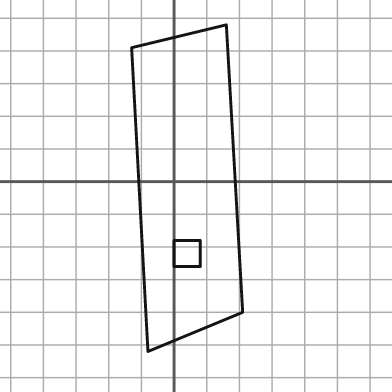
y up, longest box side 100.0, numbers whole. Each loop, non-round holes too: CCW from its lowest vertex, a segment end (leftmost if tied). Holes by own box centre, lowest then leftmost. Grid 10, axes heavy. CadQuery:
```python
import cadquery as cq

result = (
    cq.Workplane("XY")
    .moveTo(-8.0, -52.0)
    .lineTo(21.0, -40.0)
    .lineTo(16.0, 48.0)
    .lineTo(-13.0, 41.0)
    .close()
    .moveTo(0.0, -26.0)
    .lineTo(8.0, -26.0)
    .lineTo(8.0, -18.0)
    .lineTo(0.0, -18.0)
    .close()
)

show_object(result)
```